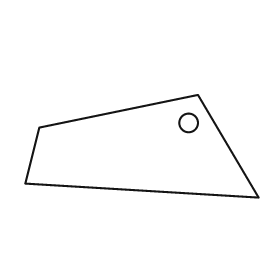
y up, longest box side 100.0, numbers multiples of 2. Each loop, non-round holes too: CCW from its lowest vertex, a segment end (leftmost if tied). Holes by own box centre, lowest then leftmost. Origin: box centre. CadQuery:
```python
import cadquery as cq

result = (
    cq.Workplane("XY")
    .moveTo(50.0, -22.0)
    .lineTo(24.0, 22.0)
    .lineTo(-44.0, 8.0)
    .lineTo(-50.0, -16.0)
    .close()
    .moveTo(20.0, 10.0)
    .circle(4.0)
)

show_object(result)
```